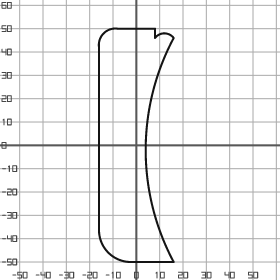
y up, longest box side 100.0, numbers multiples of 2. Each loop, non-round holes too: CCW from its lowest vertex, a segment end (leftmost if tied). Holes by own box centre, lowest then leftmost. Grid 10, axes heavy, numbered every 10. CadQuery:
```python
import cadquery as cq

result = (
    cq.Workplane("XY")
    .moveTo(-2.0, -50.0)
    .lineTo(16.0, -50.0)
    .threePointArc((4.0, -2.0), (16.0, 46.0))
    .threePointArc((12.0, 48.0), (8.0, 46.0))
    .lineTo(8.0, 50.0)
    .lineTo(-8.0, 50.0)
    .threePointArc((-14.0, 48.0), (-16.0, 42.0))
    .lineTo(-16.0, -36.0)
    .threePointArc((-12.0, -46.0), (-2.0, -50.0))
    .close()
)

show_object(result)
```